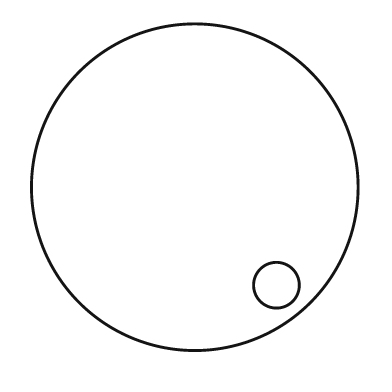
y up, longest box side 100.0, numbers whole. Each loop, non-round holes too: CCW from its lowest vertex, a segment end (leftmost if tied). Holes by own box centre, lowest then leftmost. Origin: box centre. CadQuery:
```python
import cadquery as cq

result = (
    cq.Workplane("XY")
    .moveTo(0.0, 0.0)
    .circle(50.0)
    .moveTo(25.0, -30.0)
    .circle(7.0)
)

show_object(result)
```